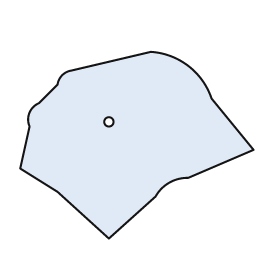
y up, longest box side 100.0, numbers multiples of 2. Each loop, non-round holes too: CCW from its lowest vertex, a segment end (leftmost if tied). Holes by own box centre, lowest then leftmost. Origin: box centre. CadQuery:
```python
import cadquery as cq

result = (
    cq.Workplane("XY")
    .moveTo(-12.0, -40.0)
    .lineTo(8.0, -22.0)
    .threePointArc((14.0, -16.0), (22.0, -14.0))
    .lineTo(50.0, -2.0)
    .lineTo(32.0, 20.0)
    .threePointArc((22.0, 34.0), (6.0, 40.0))
    .lineTo(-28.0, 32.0)
    .threePointArc((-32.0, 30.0), (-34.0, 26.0))
    .lineTo(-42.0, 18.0)
    .threePointArc((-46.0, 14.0), (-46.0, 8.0))
    .lineTo(-50.0, -10.0)
    .lineTo(-34.0, -20.0)
    .close()
    .moveTo(-12.0, 10.0)
    .circle(2.0)
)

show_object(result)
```